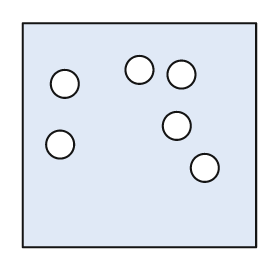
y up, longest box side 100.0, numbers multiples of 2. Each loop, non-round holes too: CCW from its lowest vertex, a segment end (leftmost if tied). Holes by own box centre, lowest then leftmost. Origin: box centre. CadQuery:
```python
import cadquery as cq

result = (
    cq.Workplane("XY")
    .moveTo(-50.0, -48.0)
    .lineTo(50.0, -48.0)
    .lineTo(50.0, 48.0)
    .lineTo(-50.0, 48.0)
    .close()
    .moveTo(28.0, -14.0)
    .circle(6.0)
    .moveTo(-34.0, -4.0)
    .circle(6.0)
    .moveTo(16.0, 4.0)
    .circle(6.0)
    .moveTo(-32.0, 22.0)
    .circle(6.0)
    .moveTo(18.0, 26.0)
    .circle(6.0)
    .moveTo(0.0, 28.0)
    .circle(6.0)
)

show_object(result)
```